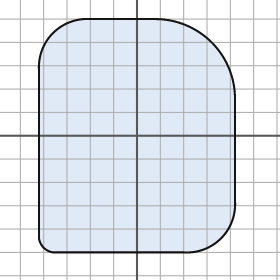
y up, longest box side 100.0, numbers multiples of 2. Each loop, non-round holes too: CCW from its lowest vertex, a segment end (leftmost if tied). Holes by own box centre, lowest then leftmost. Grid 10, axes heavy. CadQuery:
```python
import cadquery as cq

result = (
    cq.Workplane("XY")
    .moveTo(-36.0, -50.0)
    .lineTo(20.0, -50.0)
    .threePointArc((36.0, -44.0), (42.0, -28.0))
    .lineTo(42.0, 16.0)
    .threePointArc((32.0, 40.0), (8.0, 50.0))
    .lineTo(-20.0, 50.0)
    .threePointArc((-36.0, 44.0), (-42.0, 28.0))
    .lineTo(-42.0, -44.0)
    .threePointArc((-40.0, -48.0), (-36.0, -50.0))
    .close()
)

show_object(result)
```